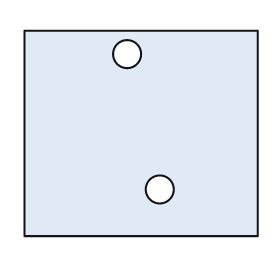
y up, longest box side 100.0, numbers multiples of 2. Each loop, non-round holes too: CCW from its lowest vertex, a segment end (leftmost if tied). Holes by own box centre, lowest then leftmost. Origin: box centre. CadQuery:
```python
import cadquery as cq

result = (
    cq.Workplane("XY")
    .moveTo(-50.0, -44.0)
    .lineTo(50.0, -44.0)
    .lineTo(50.0, 44.0)
    .lineTo(-50.0, 44.0)
    .close()
    .moveTo(8.0, -24.0)
    .circle(6.0)
    .moveTo(-6.0, 34.0)
    .circle(6.0)
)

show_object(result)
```